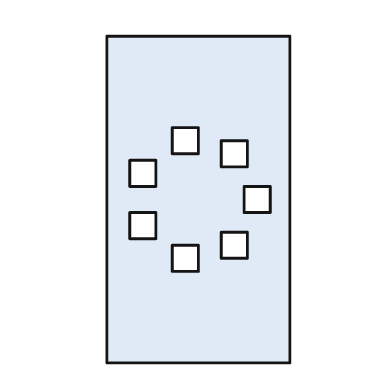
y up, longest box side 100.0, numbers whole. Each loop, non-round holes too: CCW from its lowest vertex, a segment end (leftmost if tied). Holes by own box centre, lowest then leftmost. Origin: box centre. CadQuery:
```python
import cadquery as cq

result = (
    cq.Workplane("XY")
    .moveTo(-28.0, -50.0)
    .lineTo(28.0, -50.0)
    .lineTo(28.0, 50.0)
    .lineTo(-28.0, 50.0)
    .close()
    .moveTo(-8.0, -22.0)
    .lineTo(0.0, -22.0)
    .lineTo(0.0, -14.0)
    .lineTo(-8.0, -14.0)
    .close()
    .moveTo(7.0, -18.0)
    .lineTo(15.0, -18.0)
    .lineTo(15.0, -10.0)
    .lineTo(7.0, -10.0)
    .close()
    .moveTo(-21.0, -12.0)
    .lineTo(-13.0, -12.0)
    .lineTo(-13.0, -4.0)
    .lineTo(-21.0, -4.0)
    .close()
    .moveTo(14.0, -4.0)
    .lineTo(22.0, -4.0)
    .lineTo(22.0, 4.0)
    .lineTo(14.0, 4.0)
    .close()
    .moveTo(-21.0, 4.0)
    .lineTo(-13.0, 4.0)
    .lineTo(-13.0, 12.0)
    .lineTo(-21.0, 12.0)
    .close()
    .moveTo(7.0, 10.0)
    .lineTo(15.0, 10.0)
    .lineTo(15.0, 18.0)
    .lineTo(7.0, 18.0)
    .close()
    .moveTo(-8.0, 14.0)
    .lineTo(0.0, 14.0)
    .lineTo(0.0, 22.0)
    .lineTo(-8.0, 22.0)
    .close()
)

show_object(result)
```